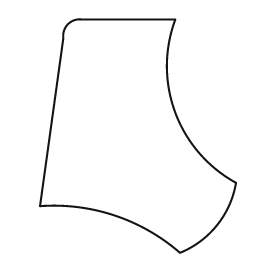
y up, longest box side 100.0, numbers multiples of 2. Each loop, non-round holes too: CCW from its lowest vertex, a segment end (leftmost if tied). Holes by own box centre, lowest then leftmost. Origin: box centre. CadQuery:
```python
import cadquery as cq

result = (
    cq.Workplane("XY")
    .moveTo(18.0, -50.0)
    .threePointArc((34.0, -38.0), (42.0, -20.0))
    .threePointArc((16.0, 10.0), (16.0, 50.0))
    .lineTo(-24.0, 50.0)
    .threePointArc((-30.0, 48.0), (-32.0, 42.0))
    .lineTo(-42.0, -30.0)
    .threePointArc((-10.0, -34.0), (18.0, -50.0))
    .close()
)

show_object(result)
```